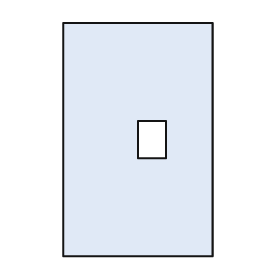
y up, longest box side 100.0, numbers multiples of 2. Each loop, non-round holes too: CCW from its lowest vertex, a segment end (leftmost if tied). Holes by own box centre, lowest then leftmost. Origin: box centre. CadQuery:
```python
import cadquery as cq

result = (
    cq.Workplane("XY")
    .moveTo(-32.0, -50.0)
    .lineTo(32.0, -50.0)
    .lineTo(32.0, 50.0)
    .lineTo(-32.0, 50.0)
    .close()
    .moveTo(0.0, -8.0)
    .lineTo(12.0, -8.0)
    .lineTo(12.0, 8.0)
    .lineTo(0.0, 8.0)
    .close()
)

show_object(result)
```